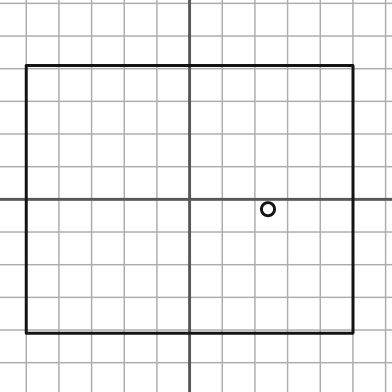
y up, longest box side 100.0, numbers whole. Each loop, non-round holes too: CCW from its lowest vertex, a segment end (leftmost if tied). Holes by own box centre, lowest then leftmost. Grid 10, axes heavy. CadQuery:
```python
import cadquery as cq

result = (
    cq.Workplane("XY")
    .moveTo(-50.0, -41.0)
    .lineTo(50.0, -41.0)
    .lineTo(50.0, 41.0)
    .lineTo(-50.0, 41.0)
    .close()
    .moveTo(24.0, -3.0)
    .circle(2.0)
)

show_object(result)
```